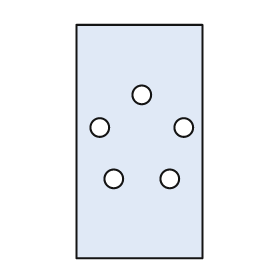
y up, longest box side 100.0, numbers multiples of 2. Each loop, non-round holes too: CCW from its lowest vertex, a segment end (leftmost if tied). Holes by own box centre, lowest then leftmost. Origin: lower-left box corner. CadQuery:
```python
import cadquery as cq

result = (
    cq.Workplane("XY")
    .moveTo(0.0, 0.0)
    .lineTo(54.0, 0.0)
    .lineTo(54.0, 100.0)
    .lineTo(0.0, 100.0)
    .close()
    .moveTo(16.0, 34.0)
    .circle(4.0)
    .moveTo(40.0, 34.0)
    .circle(4.0)
    .moveTo(10.0, 56.0)
    .circle(4.0)
    .moveTo(46.0, 56.0)
    .circle(4.0)
    .moveTo(28.0, 70.0)
    .circle(4.0)
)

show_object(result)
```